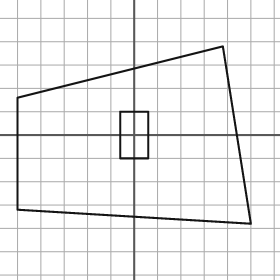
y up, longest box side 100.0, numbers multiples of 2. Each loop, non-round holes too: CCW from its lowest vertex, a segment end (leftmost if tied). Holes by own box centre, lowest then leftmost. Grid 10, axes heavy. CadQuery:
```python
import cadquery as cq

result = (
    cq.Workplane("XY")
    .moveTo(50.0, -38.0)
    .lineTo(38.0, 38.0)
    .lineTo(-50.0, 16.0)
    .lineTo(-50.0, -32.0)
    .close()
    .moveTo(-6.0, -10.0)
    .lineTo(6.0, -10.0)
    .lineTo(6.0, 10.0)
    .lineTo(-6.0, 10.0)
    .close()
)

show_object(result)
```